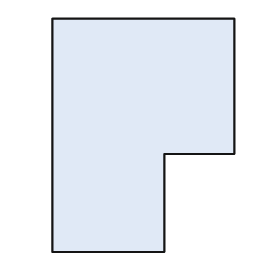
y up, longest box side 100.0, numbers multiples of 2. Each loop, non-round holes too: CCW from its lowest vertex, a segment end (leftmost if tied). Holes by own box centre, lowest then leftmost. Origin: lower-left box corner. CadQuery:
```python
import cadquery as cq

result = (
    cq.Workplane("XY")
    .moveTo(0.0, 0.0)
    .lineTo(48.0, 0.0)
    .lineTo(48.0, 42.0)
    .lineTo(78.0, 42.0)
    .lineTo(78.0, 100.0)
    .lineTo(0.0, 100.0)
    .close()
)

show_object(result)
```